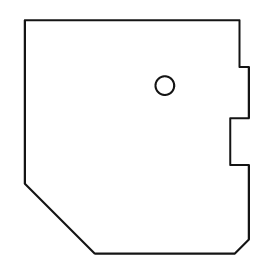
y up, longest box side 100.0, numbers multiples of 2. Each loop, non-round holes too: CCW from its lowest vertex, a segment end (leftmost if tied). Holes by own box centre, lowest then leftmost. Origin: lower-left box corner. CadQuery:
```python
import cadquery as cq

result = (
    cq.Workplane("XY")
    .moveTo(30.0, 0.0)
    .lineTo(90.0, 0.0)
    .lineTo(96.0, 6.0)
    .lineTo(96.0, 38.0)
    .lineTo(88.0, 38.0)
    .lineTo(88.0, 58.0)
    .lineTo(96.0, 58.0)
    .lineTo(96.0, 80.0)
    .lineTo(92.0, 80.0)
    .lineTo(92.0, 100.0)
    .lineTo(0.0, 100.0)
    .lineTo(0.0, 30.0)
    .close()
    .moveTo(60.0, 72.0)
    .circle(4.0)
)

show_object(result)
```